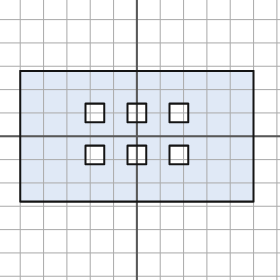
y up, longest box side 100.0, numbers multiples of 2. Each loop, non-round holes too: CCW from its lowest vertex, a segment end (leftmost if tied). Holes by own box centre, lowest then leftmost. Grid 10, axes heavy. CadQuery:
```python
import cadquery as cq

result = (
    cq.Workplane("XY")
    .moveTo(-50.0, -28.0)
    .lineTo(50.0, -28.0)
    .lineTo(50.0, 28.0)
    .lineTo(-50.0, 28.0)
    .close()
    .moveTo(-22.0, -12.0)
    .lineTo(-14.0, -12.0)
    .lineTo(-14.0, -4.0)
    .lineTo(-22.0, -4.0)
    .close()
    .moveTo(-4.0, -12.0)
    .lineTo(4.0, -12.0)
    .lineTo(4.0, -4.0)
    .lineTo(-4.0, -4.0)
    .close()
    .moveTo(14.0, -12.0)
    .lineTo(22.0, -12.0)
    .lineTo(22.0, -4.0)
    .lineTo(14.0, -4.0)
    .close()
    .moveTo(-22.0, 6.0)
    .lineTo(-14.0, 6.0)
    .lineTo(-14.0, 14.0)
    .lineTo(-22.0, 14.0)
    .close()
    .moveTo(-4.0, 6.0)
    .lineTo(4.0, 6.0)
    .lineTo(4.0, 14.0)
    .lineTo(-4.0, 14.0)
    .close()
    .moveTo(14.0, 6.0)
    .lineTo(22.0, 6.0)
    .lineTo(22.0, 14.0)
    .lineTo(14.0, 14.0)
    .close()
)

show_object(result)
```